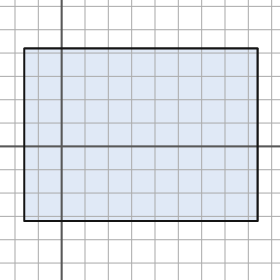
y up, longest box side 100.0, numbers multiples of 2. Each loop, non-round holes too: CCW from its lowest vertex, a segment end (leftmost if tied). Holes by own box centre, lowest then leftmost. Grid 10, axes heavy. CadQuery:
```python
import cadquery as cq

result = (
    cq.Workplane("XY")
    .moveTo(-16.0, -32.0)
    .lineTo(84.0, -32.0)
    .lineTo(84.0, 42.0)
    .lineTo(-16.0, 42.0)
    .close()
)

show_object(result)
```